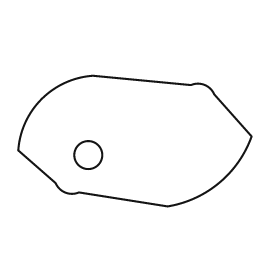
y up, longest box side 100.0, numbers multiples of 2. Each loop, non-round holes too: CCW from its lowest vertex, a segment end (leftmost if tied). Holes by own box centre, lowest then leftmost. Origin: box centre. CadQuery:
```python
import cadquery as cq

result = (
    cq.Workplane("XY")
    .moveTo(14.0, -28.0)
    .threePointArc((36.0, -18.0), (50.0, 2.0))
    .lineTo(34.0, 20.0)
    .threePointArc((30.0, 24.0), (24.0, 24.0))
    .lineTo(-18.0, 28.0)
    .threePointArc((-40.0, 18.0), (-50.0, -4.0))
    .lineTo(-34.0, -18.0)
    .threePointArc((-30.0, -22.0), (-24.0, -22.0))
    .close()
    .moveTo(-20.0, -6.0)
    .circle(6.0)
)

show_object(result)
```